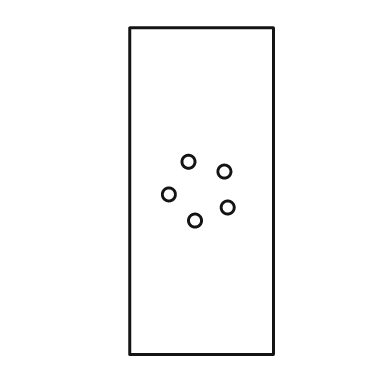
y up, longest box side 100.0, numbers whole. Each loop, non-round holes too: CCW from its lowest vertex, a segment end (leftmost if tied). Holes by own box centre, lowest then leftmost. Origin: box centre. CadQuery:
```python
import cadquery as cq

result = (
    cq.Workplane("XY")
    .moveTo(-22.0, -50.0)
    .lineTo(22.0, -50.0)
    .lineTo(22.0, 50.0)
    .lineTo(-22.0, 50.0)
    .close()
    .moveTo(-2.0, -9.0)
    .circle(2.0)
    .moveTo(8.0, -5.0)
    .circle(2.0)
    .moveTo(-10.0, -1.0)
    .circle(2.0)
    .moveTo(7.0, 6.0)
    .circle(2.0)
    .moveTo(-4.0, 9.0)
    .circle(2.0)
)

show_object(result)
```